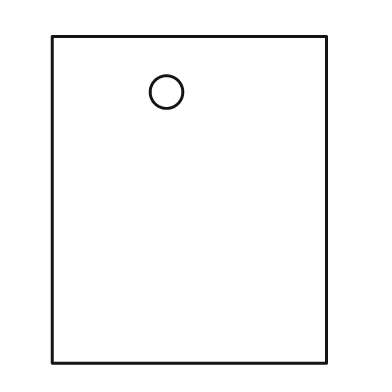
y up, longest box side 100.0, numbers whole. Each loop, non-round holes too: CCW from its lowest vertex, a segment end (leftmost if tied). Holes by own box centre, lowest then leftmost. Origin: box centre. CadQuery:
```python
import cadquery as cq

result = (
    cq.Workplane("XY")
    .moveTo(-42.0, -50.0)
    .lineTo(42.0, -50.0)
    .lineTo(42.0, 50.0)
    .lineTo(-42.0, 50.0)
    .close()
    .moveTo(-7.0, 33.0)
    .circle(5.0)
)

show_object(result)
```